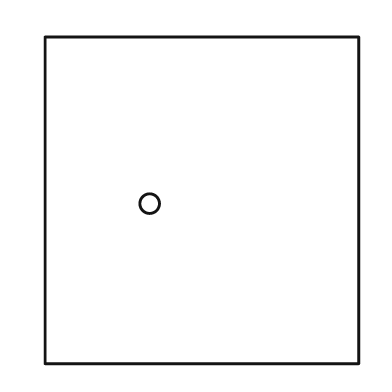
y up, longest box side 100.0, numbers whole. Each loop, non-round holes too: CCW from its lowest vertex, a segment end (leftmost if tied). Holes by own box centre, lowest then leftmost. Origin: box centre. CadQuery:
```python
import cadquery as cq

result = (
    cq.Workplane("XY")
    .moveTo(-48.0, -50.0)
    .lineTo(48.0, -50.0)
    .lineTo(48.0, 50.0)
    .lineTo(-48.0, 50.0)
    .close()
    .moveTo(-16.0, -1.0)
    .circle(3.0)
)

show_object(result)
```